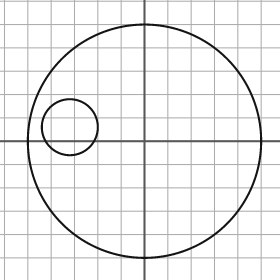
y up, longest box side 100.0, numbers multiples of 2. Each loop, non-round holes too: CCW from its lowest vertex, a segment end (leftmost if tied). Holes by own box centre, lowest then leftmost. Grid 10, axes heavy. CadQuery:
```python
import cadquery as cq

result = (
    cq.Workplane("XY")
    .moveTo(0.0, 0.0)
    .circle(50.0)
    .moveTo(-32.0, 6.0)
    .circle(12.0)
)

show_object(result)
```